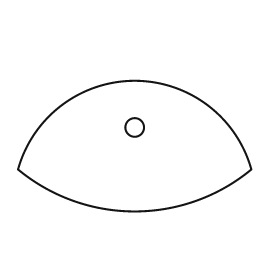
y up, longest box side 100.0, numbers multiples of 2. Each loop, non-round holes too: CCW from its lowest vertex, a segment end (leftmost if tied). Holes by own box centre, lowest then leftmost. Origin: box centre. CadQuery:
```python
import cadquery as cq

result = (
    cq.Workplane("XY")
    .moveTo(-50.0, -10.0)
    .threePointArc((0.0, -28.0), (50.0, -10.0))
    .threePointArc((0.0, 28.0), (-50.0, -10.0))
    .close()
    .moveTo(0.0, 8.0)
    .circle(4.0)
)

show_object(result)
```